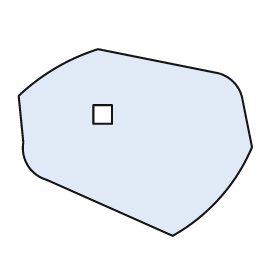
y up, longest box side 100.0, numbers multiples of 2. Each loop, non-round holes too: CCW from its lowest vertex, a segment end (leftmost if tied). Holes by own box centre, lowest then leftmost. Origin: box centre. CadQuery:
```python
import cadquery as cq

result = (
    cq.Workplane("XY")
    .moveTo(16.0, -40.0)
    .threePointArc((36.0, -24.0), (50.0, -2.0))
    .lineTo(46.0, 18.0)
    .threePointArc((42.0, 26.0), (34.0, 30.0))
    .lineTo(-16.0, 40.0)
    .threePointArc((-34.0, 32.0), (-50.0, 20.0))
    .lineTo(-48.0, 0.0)
    .threePointArc((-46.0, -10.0), (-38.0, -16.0))
    .close()
    .moveTo(-18.0, 8.0)
    .lineTo(-10.0, 8.0)
    .lineTo(-10.0, 16.0)
    .lineTo(-18.0, 16.0)
    .close()
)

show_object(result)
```